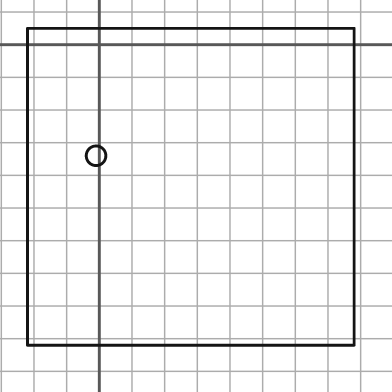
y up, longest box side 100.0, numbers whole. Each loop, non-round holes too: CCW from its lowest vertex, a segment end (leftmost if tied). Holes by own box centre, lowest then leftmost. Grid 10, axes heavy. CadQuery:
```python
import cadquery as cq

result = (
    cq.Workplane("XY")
    .moveTo(-22.0, -92.0)
    .lineTo(78.0, -92.0)
    .lineTo(78.0, 5.0)
    .lineTo(-22.0, 5.0)
    .close()
    .moveTo(-1.0, -34.0)
    .circle(3.0)
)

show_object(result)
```